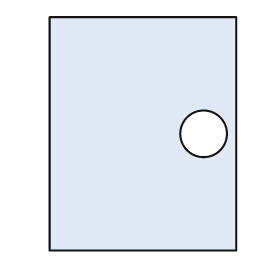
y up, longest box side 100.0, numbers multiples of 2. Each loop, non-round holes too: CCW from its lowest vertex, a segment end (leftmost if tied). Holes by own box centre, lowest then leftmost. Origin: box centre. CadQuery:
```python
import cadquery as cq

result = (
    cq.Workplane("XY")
    .moveTo(-40.0, -50.0)
    .lineTo(40.0, -50.0)
    .lineTo(40.0, 50.0)
    .lineTo(-40.0, 50.0)
    .close()
    .moveTo(26.0, 0.0)
    .circle(10.0)
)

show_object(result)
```